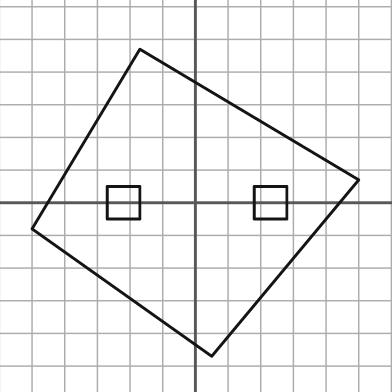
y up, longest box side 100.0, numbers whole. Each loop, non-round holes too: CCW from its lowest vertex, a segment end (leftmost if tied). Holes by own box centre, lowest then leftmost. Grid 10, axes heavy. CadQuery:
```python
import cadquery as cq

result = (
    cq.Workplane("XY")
    .moveTo(5.0, -47.0)
    .lineTo(50.0, 7.0)
    .lineTo(-17.0, 47.0)
    .lineTo(-50.0, -8.0)
    .close()
    .moveTo(-27.0, -5.0)
    .lineTo(-17.0, -5.0)
    .lineTo(-17.0, 5.0)
    .lineTo(-27.0, 5.0)
    .close()
    .moveTo(18.0, -5.0)
    .lineTo(28.0, -5.0)
    .lineTo(28.0, 5.0)
    .lineTo(18.0, 5.0)
    .close()
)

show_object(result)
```